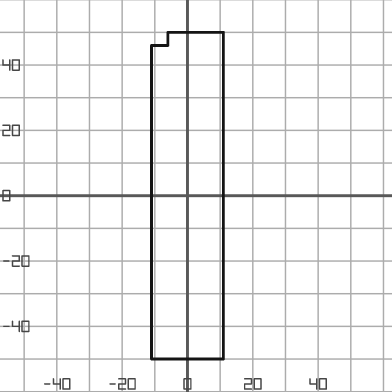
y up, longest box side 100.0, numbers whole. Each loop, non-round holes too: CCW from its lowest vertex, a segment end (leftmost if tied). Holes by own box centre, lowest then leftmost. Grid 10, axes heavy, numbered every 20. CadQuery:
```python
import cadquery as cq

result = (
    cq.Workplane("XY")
    .moveTo(-11.0, -50.0)
    .lineTo(11.0, -50.0)
    .lineTo(11.0, 50.0)
    .lineTo(-6.0, 50.0)
    .lineTo(-6.0, 46.0)
    .lineTo(-11.0, 46.0)
    .close()
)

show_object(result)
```